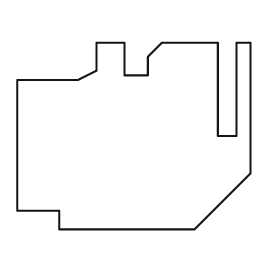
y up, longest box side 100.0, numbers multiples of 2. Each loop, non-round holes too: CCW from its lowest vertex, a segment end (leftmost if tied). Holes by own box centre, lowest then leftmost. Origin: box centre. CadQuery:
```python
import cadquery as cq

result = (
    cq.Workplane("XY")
    .moveTo(-32.0, -40.0)
    .lineTo(26.0, -40.0)
    .lineTo(50.0, -16.0)
    .lineTo(50.0, 40.0)
    .lineTo(44.0, 40.0)
    .lineTo(44.0, 0.0)
    .lineTo(36.0, 0.0)
    .lineTo(36.0, 40.0)
    .lineTo(12.0, 40.0)
    .lineTo(6.0, 34.0)
    .lineTo(6.0, 26.0)
    .lineTo(-4.0, 26.0)
    .lineTo(-4.0, 40.0)
    .lineTo(-16.0, 40.0)
    .lineTo(-16.0, 28.0)
    .lineTo(-24.0, 24.0)
    .lineTo(-50.0, 24.0)
    .lineTo(-50.0, -32.0)
    .lineTo(-32.0, -32.0)
    .close()
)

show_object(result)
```